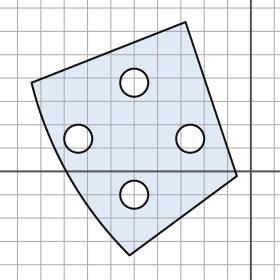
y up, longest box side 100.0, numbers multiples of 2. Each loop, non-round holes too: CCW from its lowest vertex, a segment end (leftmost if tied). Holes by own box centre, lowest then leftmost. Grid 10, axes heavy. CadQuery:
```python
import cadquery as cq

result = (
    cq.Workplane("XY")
    .moveTo(-52.0, -36.0)
    .lineTo(-6.0, -2.0)
    .lineTo(-28.0, 64.0)
    .lineTo(-94.0, 38.0)
    .threePointArc((-78.0, -2.0), (-52.0, -36.0))
    .close()
    .moveTo(-50.0, -10.0)
    .circle(6.0)
    .moveTo(-74.0, 14.0)
    .circle(6.0)
    .moveTo(-26.0, 14.0)
    .circle(6.0)
    .moveTo(-50.0, 38.0)
    .circle(6.0)
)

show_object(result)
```